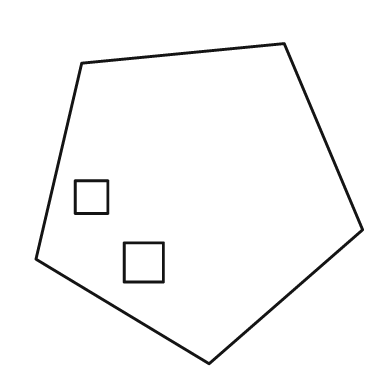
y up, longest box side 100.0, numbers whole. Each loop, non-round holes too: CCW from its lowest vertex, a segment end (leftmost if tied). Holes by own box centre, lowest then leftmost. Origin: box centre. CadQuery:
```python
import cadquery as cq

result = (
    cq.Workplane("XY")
    .moveTo(3.0, -49.0)
    .lineTo(50.0, -8.0)
    .lineTo(26.0, 49.0)
    .lineTo(-36.0, 43.0)
    .lineTo(-50.0, -17.0)
    .close()
    .moveTo(-23.0, -24.0)
    .lineTo(-11.0, -24.0)
    .lineTo(-11.0, -12.0)
    .lineTo(-23.0, -12.0)
    .close()
    .moveTo(-38.0, -3.0)
    .lineTo(-28.0, -3.0)
    .lineTo(-28.0, 7.0)
    .lineTo(-38.0, 7.0)
    .close()
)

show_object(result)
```